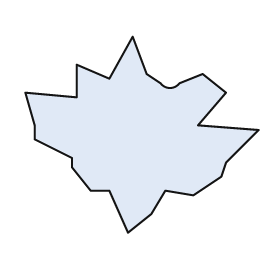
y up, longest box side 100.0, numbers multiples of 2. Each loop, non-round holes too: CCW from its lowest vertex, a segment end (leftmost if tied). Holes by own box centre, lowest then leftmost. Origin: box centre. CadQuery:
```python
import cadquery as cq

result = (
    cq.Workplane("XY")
    .moveTo(-6.0, -42.0)
    .lineTo(4.0, -34.0)
    .lineTo(10.0, -24.0)
    .lineTo(22.0, -26.0)
    .lineTo(34.0, -18.0)
    .lineTo(36.0, -12.0)
    .lineTo(50.0, 2.0)
    .lineTo(24.0, 4.0)
    .lineTo(36.0, 18.0)
    .lineTo(26.0, 26.0)
    .lineTo(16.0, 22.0)
    .threePointArc((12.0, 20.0), (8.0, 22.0))
    .lineTo(2.0, 26.0)
    .lineTo(-4.0, 42.0)
    .lineTo(-14.0, 24.0)
    .lineTo(-28.0, 30.0)
    .lineTo(-28.0, 16.0)
    .lineTo(-50.0, 18.0)
    .lineTo(-46.0, 4.0)
    .lineTo(-46.0, -2.0)
    .lineTo(-30.0, -10.0)
    .lineTo(-30.0, -14.0)
    .lineTo(-22.0, -24.0)
    .lineTo(-14.0, -24.0)
    .close()
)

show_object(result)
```